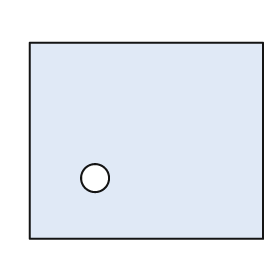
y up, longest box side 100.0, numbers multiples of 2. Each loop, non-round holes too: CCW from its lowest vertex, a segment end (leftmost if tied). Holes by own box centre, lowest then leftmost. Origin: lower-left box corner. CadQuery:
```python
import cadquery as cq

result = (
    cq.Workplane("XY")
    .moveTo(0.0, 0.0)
    .lineTo(100.0, 0.0)
    .lineTo(100.0, 84.0)
    .lineTo(0.0, 84.0)
    .close()
    .moveTo(28.0, 26.0)
    .circle(6.0)
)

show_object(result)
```